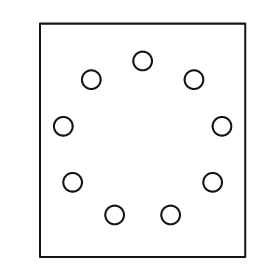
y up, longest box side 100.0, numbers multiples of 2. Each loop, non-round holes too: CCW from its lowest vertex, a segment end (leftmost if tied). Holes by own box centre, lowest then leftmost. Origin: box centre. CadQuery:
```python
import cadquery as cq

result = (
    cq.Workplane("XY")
    .moveTo(-44.0, -50.0)
    .lineTo(44.0, -50.0)
    .lineTo(44.0, 50.0)
    .lineTo(-44.0, 50.0)
    .close()
    .moveTo(-12.0, -32.0)
    .circle(4.0)
    .moveTo(12.0, -32.0)
    .circle(4.0)
    .moveTo(-30.0, -18.0)
    .circle(4.0)
    .moveTo(30.0, -18.0)
    .circle(4.0)
    .moveTo(-34.0, 6.0)
    .circle(4.0)
    .moveTo(34.0, 6.0)
    .circle(4.0)
    .moveTo(-22.0, 26.0)
    .circle(4.0)
    .moveTo(22.0, 26.0)
    .circle(4.0)
    .moveTo(0.0, 34.0)
    .circle(4.0)
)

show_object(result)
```